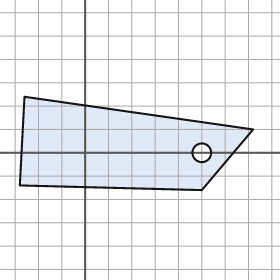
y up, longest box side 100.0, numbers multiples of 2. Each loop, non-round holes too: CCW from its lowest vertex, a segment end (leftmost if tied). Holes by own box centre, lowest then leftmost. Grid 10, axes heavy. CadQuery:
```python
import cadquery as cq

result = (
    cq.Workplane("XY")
    .moveTo(50.0, -16.0)
    .lineTo(72.0, 10.0)
    .lineTo(-26.0, 24.0)
    .lineTo(-28.0, -14.0)
    .close()
    .moveTo(50.0, 0.0)
    .circle(4.0)
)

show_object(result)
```